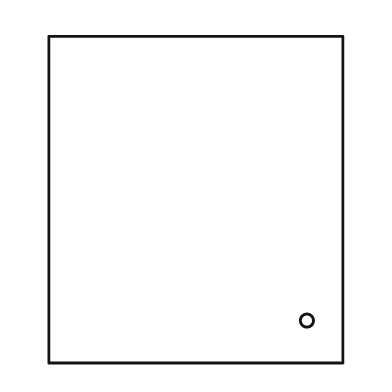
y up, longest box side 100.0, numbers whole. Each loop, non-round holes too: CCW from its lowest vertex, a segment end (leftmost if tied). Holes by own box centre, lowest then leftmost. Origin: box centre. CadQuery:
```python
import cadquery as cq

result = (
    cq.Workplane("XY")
    .moveTo(-45.0, -50.0)
    .lineTo(45.0, -50.0)
    .lineTo(45.0, 50.0)
    .lineTo(-45.0, 50.0)
    .close()
    .moveTo(34.0, -37.0)
    .circle(2.0)
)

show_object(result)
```